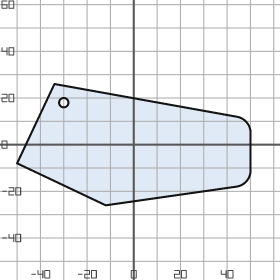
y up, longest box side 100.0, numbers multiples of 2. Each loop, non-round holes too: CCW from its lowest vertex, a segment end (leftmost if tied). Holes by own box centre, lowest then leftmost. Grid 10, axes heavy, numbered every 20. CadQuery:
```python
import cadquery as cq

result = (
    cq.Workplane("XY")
    .moveTo(-12.0, -26.0)
    .lineTo(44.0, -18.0)
    .threePointArc((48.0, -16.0), (50.0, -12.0))
    .lineTo(50.0, 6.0)
    .threePointArc((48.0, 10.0), (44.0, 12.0))
    .lineTo(-34.0, 26.0)
    .lineTo(-50.0, -8.0)
    .close()
    .moveTo(-30.0, 18.0)
    .circle(2.0)
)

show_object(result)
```